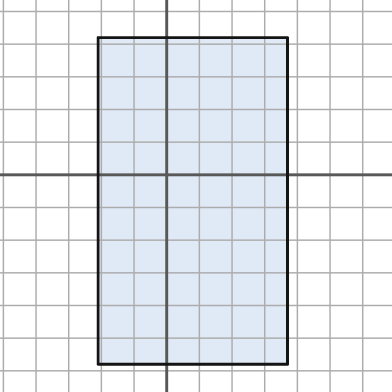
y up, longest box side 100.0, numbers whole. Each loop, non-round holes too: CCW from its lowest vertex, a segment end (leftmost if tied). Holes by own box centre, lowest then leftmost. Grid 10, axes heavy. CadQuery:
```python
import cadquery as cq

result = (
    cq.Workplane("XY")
    .moveTo(-21.0, -58.0)
    .lineTo(37.0, -58.0)
    .lineTo(37.0, 42.0)
    .lineTo(-21.0, 42.0)
    .close()
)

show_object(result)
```